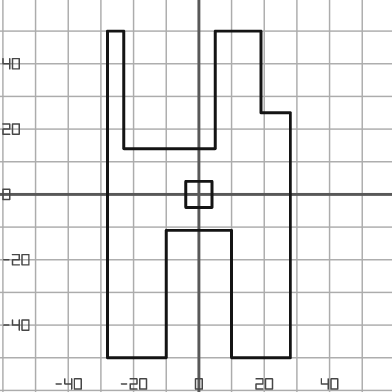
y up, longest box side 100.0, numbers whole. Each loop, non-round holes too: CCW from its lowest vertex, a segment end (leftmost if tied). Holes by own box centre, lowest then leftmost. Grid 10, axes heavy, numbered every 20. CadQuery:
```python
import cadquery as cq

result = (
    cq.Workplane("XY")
    .moveTo(-28.0, -50.0)
    .lineTo(-10.0, -50.0)
    .lineTo(-10.0, -11.0)
    .lineTo(10.0, -11.0)
    .lineTo(10.0, -50.0)
    .lineTo(28.0, -50.0)
    .lineTo(28.0, 25.0)
    .lineTo(19.0, 25.0)
    .lineTo(19.0, 50.0)
    .lineTo(5.0, 50.0)
    .lineTo(5.0, 14.0)
    .lineTo(-23.0, 14.0)
    .lineTo(-23.0, 50.0)
    .lineTo(-28.0, 50.0)
    .close()
    .moveTo(-4.0, -4.0)
    .lineTo(4.0, -4.0)
    .lineTo(4.0, 4.0)
    .lineTo(-4.0, 4.0)
    .close()
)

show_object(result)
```